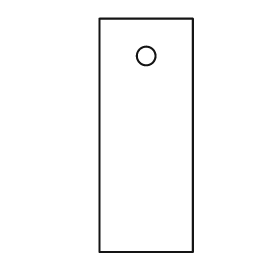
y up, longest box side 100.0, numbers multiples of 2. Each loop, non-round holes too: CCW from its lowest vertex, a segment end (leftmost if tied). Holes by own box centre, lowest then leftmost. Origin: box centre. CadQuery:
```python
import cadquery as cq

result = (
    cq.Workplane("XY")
    .moveTo(-20.0, -50.0)
    .lineTo(20.0, -50.0)
    .lineTo(20.0, 50.0)
    .lineTo(-20.0, 50.0)
    .close()
    .moveTo(0.0, 34.0)
    .circle(4.0)
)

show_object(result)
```